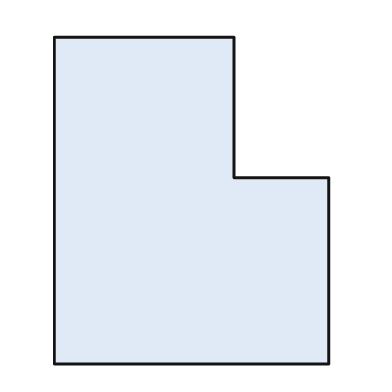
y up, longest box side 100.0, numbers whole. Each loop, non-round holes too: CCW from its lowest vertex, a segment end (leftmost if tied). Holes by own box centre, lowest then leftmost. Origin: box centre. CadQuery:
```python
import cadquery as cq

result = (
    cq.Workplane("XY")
    .moveTo(-42.0, -50.0)
    .lineTo(42.0, -50.0)
    .lineTo(42.0, 7.0)
    .lineTo(13.0, 7.0)
    .lineTo(13.0, 50.0)
    .lineTo(-42.0, 50.0)
    .close()
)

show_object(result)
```